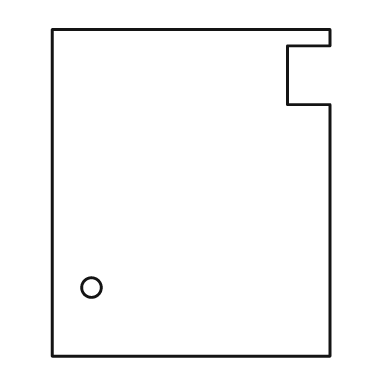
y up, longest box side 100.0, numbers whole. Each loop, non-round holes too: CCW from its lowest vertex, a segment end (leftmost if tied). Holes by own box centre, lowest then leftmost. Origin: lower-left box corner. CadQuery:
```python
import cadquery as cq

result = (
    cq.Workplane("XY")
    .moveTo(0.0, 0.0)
    .lineTo(85.0, 0.0)
    .lineTo(85.0, 77.0)
    .lineTo(72.0, 77.0)
    .lineTo(72.0, 95.0)
    .lineTo(85.0, 95.0)
    .lineTo(85.0, 100.0)
    .lineTo(0.0, 100.0)
    .close()
    .moveTo(12.0, 21.0)
    .circle(3.0)
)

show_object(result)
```